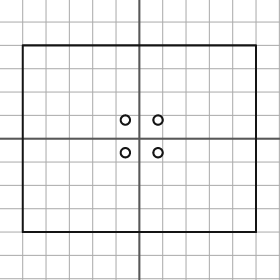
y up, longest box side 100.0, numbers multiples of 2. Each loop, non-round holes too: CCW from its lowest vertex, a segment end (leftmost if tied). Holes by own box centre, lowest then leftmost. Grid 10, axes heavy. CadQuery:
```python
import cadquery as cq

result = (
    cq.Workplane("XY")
    .moveTo(-50.0, -40.0)
    .lineTo(50.0, -40.0)
    .lineTo(50.0, 40.0)
    .lineTo(-50.0, 40.0)
    .close()
    .moveTo(-6.0, -6.0)
    .circle(2.0)
    .moveTo(8.0, -6.0)
    .circle(2.0)
    .moveTo(-6.0, 8.0)
    .circle(2.0)
    .moveTo(8.0, 8.0)
    .circle(2.0)
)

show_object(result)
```